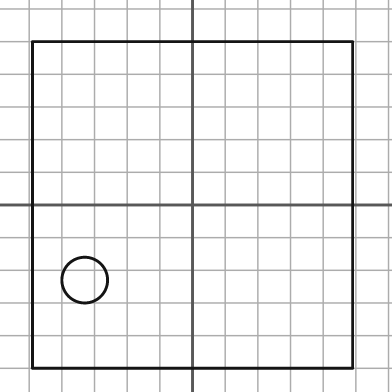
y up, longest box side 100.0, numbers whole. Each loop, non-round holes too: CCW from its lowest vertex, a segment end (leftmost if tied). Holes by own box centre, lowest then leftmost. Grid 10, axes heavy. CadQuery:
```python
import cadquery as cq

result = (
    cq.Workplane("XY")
    .moveTo(-49.0, -50.0)
    .lineTo(49.0, -50.0)
    .lineTo(49.0, 50.0)
    .lineTo(-49.0, 50.0)
    .close()
    .moveTo(-33.0, -23.0)
    .circle(7.0)
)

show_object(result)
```